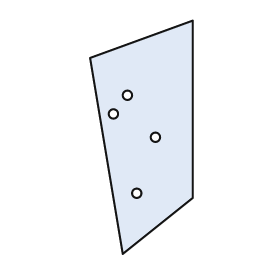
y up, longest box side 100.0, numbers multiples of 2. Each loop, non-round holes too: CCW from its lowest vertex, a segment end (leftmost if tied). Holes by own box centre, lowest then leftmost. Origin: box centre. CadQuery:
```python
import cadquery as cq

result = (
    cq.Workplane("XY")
    .moveTo(-8.0, -50.0)
    .lineTo(22.0, -26.0)
    .lineTo(22.0, 50.0)
    .lineTo(-22.0, 34.0)
    .close()
    .moveTo(-2.0, -24.0)
    .circle(2.0)
    .moveTo(6.0, 0.0)
    .circle(2.0)
    .moveTo(-12.0, 10.0)
    .circle(2.0)
    .moveTo(-6.0, 18.0)
    .circle(2.0)
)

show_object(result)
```